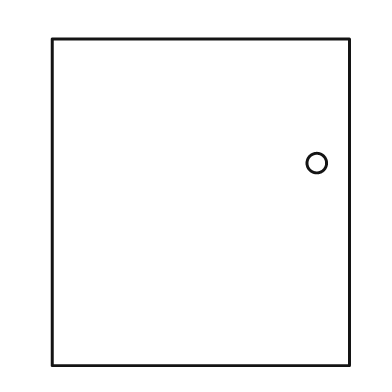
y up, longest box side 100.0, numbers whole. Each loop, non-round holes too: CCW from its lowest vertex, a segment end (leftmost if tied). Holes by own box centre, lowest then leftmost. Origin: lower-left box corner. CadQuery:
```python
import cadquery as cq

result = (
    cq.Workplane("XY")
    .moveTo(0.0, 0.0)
    .lineTo(91.0, 0.0)
    .lineTo(91.0, 100.0)
    .lineTo(0.0, 100.0)
    .close()
    .moveTo(81.0, 62.0)
    .circle(3.0)
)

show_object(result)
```